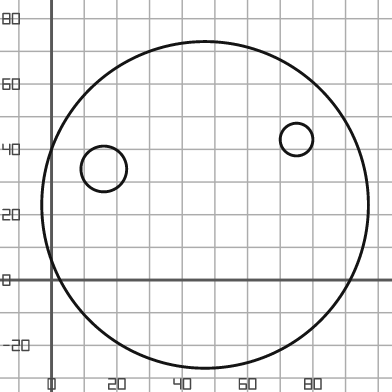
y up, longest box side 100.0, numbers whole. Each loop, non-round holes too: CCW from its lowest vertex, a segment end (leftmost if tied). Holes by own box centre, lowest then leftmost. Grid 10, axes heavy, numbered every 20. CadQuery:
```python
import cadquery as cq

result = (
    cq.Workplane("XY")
    .moveTo(47.0, 23.0)
    .circle(50.0)
    .moveTo(16.0, 34.0)
    .circle(7.0)
    .moveTo(75.0, 43.0)
    .circle(5.0)
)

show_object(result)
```